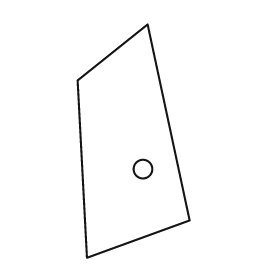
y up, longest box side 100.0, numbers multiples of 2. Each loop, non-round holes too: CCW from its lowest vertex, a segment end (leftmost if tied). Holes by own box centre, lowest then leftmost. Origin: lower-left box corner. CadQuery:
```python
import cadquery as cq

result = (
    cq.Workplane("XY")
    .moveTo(4.0, 0.0)
    .lineTo(48.0, 16.0)
    .lineTo(30.0, 100.0)
    .lineTo(0.0, 76.0)
    .close()
    .moveTo(28.0, 38.0)
    .circle(4.0)
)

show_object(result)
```